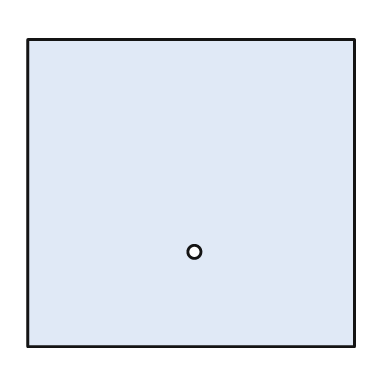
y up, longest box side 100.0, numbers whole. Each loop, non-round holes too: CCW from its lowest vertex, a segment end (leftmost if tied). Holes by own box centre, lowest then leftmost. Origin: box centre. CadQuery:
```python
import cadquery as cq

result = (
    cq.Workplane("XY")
    .moveTo(-50.0, -47.0)
    .lineTo(50.0, -47.0)
    .lineTo(50.0, 47.0)
    .lineTo(-50.0, 47.0)
    .close()
    .moveTo(1.0, -18.0)
    .circle(2.0)
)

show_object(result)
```